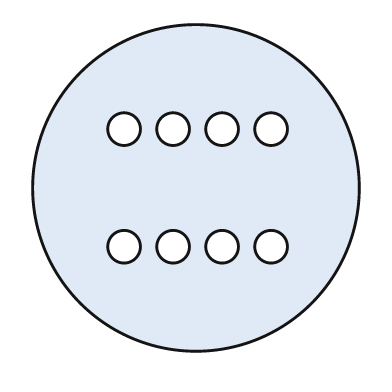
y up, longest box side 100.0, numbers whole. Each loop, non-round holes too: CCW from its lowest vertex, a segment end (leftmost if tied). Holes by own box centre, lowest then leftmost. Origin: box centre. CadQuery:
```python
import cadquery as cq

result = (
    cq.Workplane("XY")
    .moveTo(0.0, 0.0)
    .circle(50.0)
    .moveTo(-22.0, -18.0)
    .circle(5.0)
    .moveTo(-7.0, -18.0)
    .circle(5.0)
    .moveTo(8.0, -18.0)
    .circle(5.0)
    .moveTo(23.0, -18.0)
    .circle(5.0)
    .moveTo(-22.0, 18.0)
    .circle(5.0)
    .moveTo(-7.0, 18.0)
    .circle(5.0)
    .moveTo(8.0, 18.0)
    .circle(5.0)
    .moveTo(23.0, 18.0)
    .circle(5.0)
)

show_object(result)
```